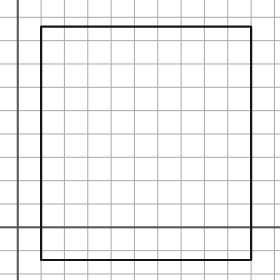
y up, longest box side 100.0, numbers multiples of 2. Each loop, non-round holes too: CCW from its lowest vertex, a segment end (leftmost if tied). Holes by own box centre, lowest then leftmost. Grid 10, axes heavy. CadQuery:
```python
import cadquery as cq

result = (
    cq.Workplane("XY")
    .moveTo(10.0, -14.0)
    .lineTo(100.0, -14.0)
    .lineTo(100.0, 86.0)
    .lineTo(10.0, 86.0)
    .close()
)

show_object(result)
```